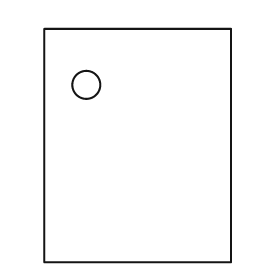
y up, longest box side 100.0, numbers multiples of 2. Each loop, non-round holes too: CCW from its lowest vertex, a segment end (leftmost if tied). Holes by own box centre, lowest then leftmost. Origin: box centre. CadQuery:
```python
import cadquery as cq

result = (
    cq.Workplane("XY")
    .moveTo(-40.0, -50.0)
    .lineTo(40.0, -50.0)
    .lineTo(40.0, 50.0)
    .lineTo(-40.0, 50.0)
    .close()
    .moveTo(-22.0, 26.0)
    .circle(6.0)
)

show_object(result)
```